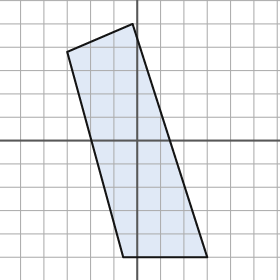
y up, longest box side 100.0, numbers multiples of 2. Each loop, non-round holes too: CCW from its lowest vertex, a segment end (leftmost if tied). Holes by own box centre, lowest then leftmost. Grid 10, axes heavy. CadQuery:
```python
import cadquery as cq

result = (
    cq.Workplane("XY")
    .moveTo(-6.0, -50.0)
    .lineTo(30.0, -50.0)
    .lineTo(-2.0, 50.0)
    .lineTo(-30.0, 38.0)
    .close()
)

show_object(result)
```